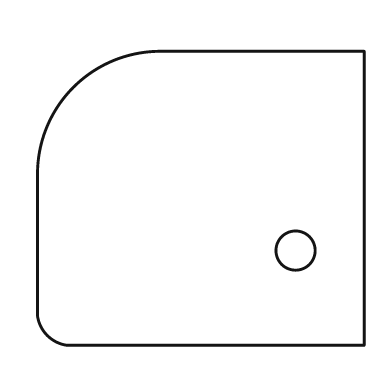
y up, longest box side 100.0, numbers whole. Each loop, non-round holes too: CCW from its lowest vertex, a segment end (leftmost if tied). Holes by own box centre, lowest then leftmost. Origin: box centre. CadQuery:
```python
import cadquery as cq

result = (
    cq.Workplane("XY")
    .moveTo(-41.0, -45.0)
    .lineTo(50.0, -45.0)
    .lineTo(50.0, 45.0)
    .lineTo(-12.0, 45.0)
    .threePointArc((-39.0, 34.0), (-50.0, 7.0))
    .lineTo(-50.0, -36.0)
    .threePointArc((-47.0, -42.0), (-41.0, -45.0))
    .close()
    .moveTo(29.0, -16.0)
    .circle(6.0)
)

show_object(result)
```